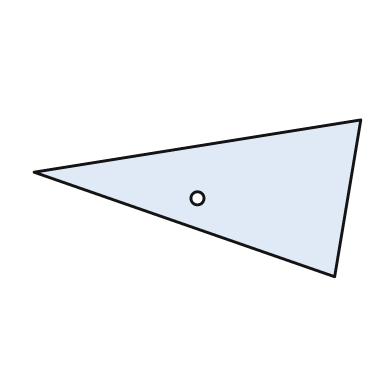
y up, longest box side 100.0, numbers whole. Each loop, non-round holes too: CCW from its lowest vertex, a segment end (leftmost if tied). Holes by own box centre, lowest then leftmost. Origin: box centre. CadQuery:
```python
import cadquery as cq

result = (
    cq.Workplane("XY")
    .moveTo(42.0, -24.0)
    .lineTo(50.0, 24.0)
    .lineTo(-50.0, 8.0)
    .close()
    .moveTo(0.0, 0.0)
    .circle(2.0)
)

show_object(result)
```